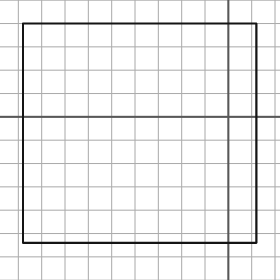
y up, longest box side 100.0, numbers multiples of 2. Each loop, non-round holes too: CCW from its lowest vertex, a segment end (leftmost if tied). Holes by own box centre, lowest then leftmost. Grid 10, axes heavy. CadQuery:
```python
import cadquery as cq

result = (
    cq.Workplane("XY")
    .moveTo(-88.0, -54.0)
    .lineTo(12.0, -54.0)
    .lineTo(12.0, 40.0)
    .lineTo(-88.0, 40.0)
    .close()
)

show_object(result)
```